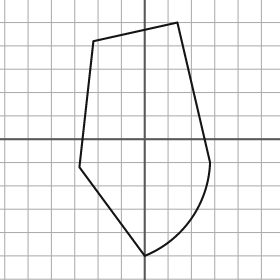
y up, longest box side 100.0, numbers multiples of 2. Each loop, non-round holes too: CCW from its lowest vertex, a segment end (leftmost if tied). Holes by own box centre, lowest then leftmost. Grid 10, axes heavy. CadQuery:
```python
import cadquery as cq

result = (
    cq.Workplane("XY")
    .moveTo(0.0, -50.0)
    .threePointArc((20.0, -34.0), (28.0, -10.0))
    .lineTo(14.0, 50.0)
    .lineTo(-22.0, 42.0)
    .lineTo(-28.0, -12.0)
    .close()
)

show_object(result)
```